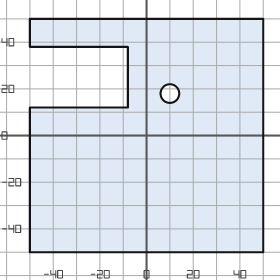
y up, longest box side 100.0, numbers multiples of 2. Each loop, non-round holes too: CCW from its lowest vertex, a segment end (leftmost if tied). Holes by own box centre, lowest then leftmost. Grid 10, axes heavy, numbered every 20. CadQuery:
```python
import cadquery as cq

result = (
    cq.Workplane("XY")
    .moveTo(-50.0, -50.0)
    .lineTo(50.0, -50.0)
    .lineTo(50.0, 50.0)
    .lineTo(-50.0, 50.0)
    .lineTo(-50.0, 38.0)
    .lineTo(-8.0, 38.0)
    .lineTo(-8.0, 12.0)
    .lineTo(-50.0, 12.0)
    .close()
    .moveTo(10.0, 18.0)
    .circle(4.0)
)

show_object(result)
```